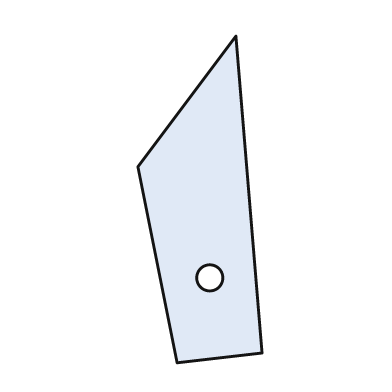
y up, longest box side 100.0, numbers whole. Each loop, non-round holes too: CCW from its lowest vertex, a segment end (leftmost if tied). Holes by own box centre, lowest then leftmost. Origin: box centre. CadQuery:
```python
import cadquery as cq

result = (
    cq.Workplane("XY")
    .moveTo(-7.0, -50.0)
    .lineTo(19.0, -47.0)
    .lineTo(11.0, 50.0)
    .lineTo(-19.0, 10.0)
    .close()
    .moveTo(3.0, -24.0)
    .circle(4.0)
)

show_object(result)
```